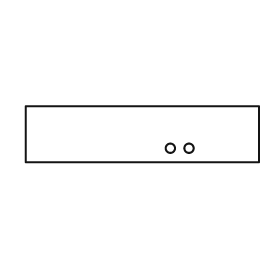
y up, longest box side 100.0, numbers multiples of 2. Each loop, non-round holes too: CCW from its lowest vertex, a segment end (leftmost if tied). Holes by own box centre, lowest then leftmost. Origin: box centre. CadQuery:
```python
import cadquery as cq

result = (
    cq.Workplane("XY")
    .moveTo(-50.0, -12.0)
    .lineTo(50.0, -12.0)
    .lineTo(50.0, 12.0)
    .lineTo(-50.0, 12.0)
    .close()
    .moveTo(12.0, -6.0)
    .circle(2.0)
    .moveTo(20.0, -6.0)
    .circle(2.0)
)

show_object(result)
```